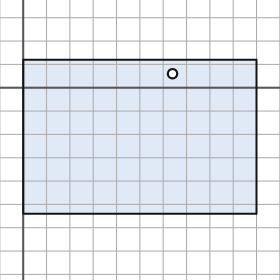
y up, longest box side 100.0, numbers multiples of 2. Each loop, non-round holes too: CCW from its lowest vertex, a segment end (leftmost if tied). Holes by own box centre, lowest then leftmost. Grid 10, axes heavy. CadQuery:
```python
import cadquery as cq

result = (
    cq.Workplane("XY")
    .moveTo(0.0, -54.0)
    .lineTo(100.0, -54.0)
    .lineTo(100.0, 12.0)
    .lineTo(0.0, 12.0)
    .close()
    .moveTo(64.0, 6.0)
    .circle(2.0)
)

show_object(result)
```